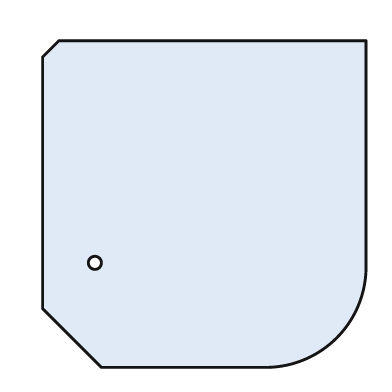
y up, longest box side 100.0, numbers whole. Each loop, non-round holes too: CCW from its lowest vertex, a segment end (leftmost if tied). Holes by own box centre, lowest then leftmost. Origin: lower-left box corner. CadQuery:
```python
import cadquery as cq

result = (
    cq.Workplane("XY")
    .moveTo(18.0, 0.0)
    .lineTo(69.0, 0.0)
    .threePointArc((90.0, 9.0), (99.0, 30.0))
    .lineTo(99.0, 100.0)
    .lineTo(5.0, 100.0)
    .lineTo(0.0, 95.0)
    .lineTo(0.0, 18.0)
    .close()
    .moveTo(16.0, 32.0)
    .circle(2.0)
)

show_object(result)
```